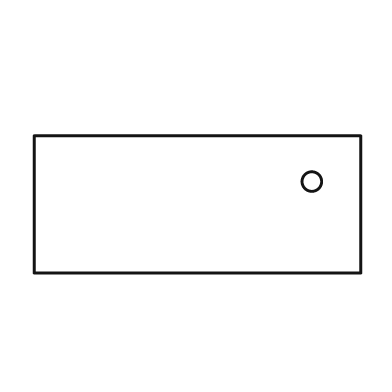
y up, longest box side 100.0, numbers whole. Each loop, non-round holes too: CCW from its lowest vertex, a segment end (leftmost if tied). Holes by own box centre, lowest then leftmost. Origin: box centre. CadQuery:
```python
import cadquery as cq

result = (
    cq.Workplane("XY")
    .moveTo(-50.0, -21.0)
    .lineTo(50.0, -21.0)
    .lineTo(50.0, 21.0)
    .lineTo(-50.0, 21.0)
    .close()
    .moveTo(35.0, 7.0)
    .circle(3.0)
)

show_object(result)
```